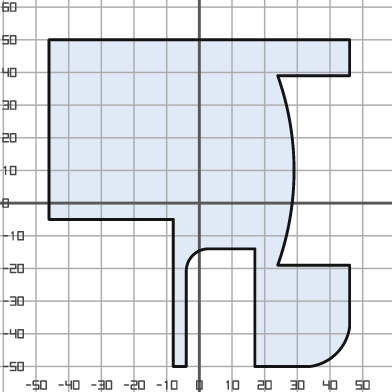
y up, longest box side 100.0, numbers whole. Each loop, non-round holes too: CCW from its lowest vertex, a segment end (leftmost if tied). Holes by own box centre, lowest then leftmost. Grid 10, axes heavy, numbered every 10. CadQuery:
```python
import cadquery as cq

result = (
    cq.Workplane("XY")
    .moveTo(-8.0, -50.0)
    .lineTo(-4.0, -50.0)
    .lineTo(-4.0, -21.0)
    .threePointArc((-2.0, -16.0), (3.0, -14.0))
    .lineTo(17.0, -14.0)
    .lineTo(17.0, -50.0)
    .lineTo(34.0, -50.0)
    .threePointArc((42.0, -46.0), (46.0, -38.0))
    .lineTo(46.0, -19.0)
    .lineTo(24.0, -19.0)
    .threePointArc((29.0, 10.0), (24.0, 39.0))
    .lineTo(46.0, 39.0)
    .lineTo(46.0, 50.0)
    .lineTo(-46.0, 50.0)
    .lineTo(-46.0, -5.0)
    .lineTo(-8.0, -5.0)
    .close()
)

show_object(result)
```